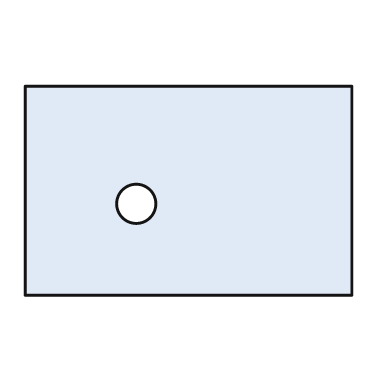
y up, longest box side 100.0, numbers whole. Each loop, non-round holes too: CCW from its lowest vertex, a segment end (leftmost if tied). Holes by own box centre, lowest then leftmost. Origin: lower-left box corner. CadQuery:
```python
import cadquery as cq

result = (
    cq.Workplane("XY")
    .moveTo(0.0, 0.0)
    .lineTo(100.0, 0.0)
    .lineTo(100.0, 64.0)
    .lineTo(0.0, 64.0)
    .close()
    .moveTo(34.0, 28.0)
    .circle(6.0)
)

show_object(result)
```